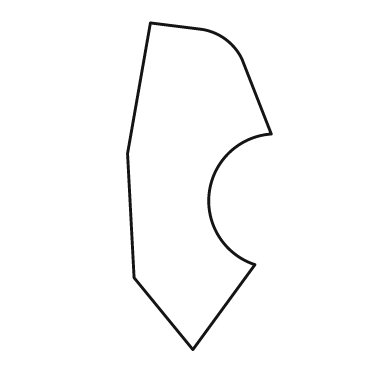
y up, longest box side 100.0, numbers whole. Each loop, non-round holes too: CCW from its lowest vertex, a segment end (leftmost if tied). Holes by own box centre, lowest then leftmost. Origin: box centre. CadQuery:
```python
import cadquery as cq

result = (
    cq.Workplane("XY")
    .moveTo(-2.0, -50.0)
    .lineTo(17.0, -24.0)
    .threePointArc((3.0, -2.0), (22.0, 16.0))
    .lineTo(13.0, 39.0)
    .threePointArc((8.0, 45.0), (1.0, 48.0))
    .lineTo(-15.0, 50.0)
    .lineTo(-22.0, 10.0)
    .lineTo(-20.0, -28.0)
    .close()
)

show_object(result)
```